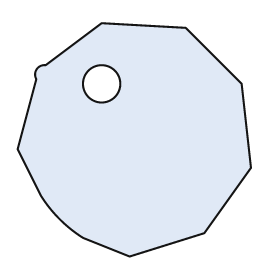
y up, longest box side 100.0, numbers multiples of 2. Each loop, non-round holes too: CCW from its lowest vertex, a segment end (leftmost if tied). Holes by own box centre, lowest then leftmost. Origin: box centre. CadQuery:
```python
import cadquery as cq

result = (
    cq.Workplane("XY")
    .moveTo(-2.0, -50.0)
    .lineTo(30.0, -40.0)
    .lineTo(50.0, -12.0)
    .lineTo(46.0, 24.0)
    .lineTo(22.0, 48.0)
    .lineTo(-14.0, 50.0)
    .lineTo(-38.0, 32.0)
    .threePointArc((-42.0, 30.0), (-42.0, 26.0))
    .lineTo(-50.0, -4.0)
    .lineTo(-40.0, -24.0)
    .threePointArc((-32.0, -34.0), (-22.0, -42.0))
    .close()
    .moveTo(-14.0, 24.0)
    .circle(8.0)
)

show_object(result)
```